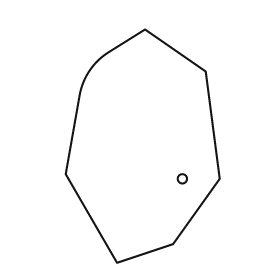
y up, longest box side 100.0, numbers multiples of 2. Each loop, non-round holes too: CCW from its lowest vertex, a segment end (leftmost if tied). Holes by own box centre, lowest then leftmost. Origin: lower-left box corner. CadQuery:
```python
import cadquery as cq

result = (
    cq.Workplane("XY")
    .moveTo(22.0, 0.0)
    .lineTo(46.0, 8.0)
    .lineTo(66.0, 36.0)
    .lineTo(60.0, 82.0)
    .lineTo(34.0, 100.0)
    .lineTo(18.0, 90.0)
    .threePointArc((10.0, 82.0), (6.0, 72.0))
    .lineTo(0.0, 38.0)
    .close()
    .moveTo(50.0, 36.0)
    .circle(2.0)
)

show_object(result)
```